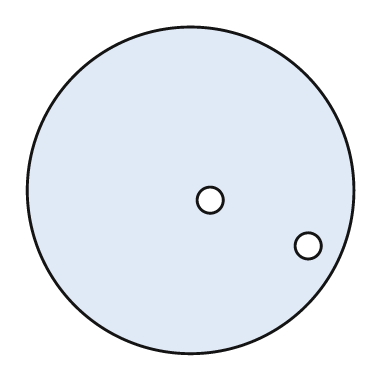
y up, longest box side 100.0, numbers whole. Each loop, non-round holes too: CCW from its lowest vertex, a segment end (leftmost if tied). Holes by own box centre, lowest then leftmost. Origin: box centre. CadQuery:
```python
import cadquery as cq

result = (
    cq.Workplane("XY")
    .moveTo(0.0, 0.0)
    .circle(50.0)
    .moveTo(36.0, -17.0)
    .circle(4.0)
    .moveTo(6.0, -3.0)
    .circle(4.0)
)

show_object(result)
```